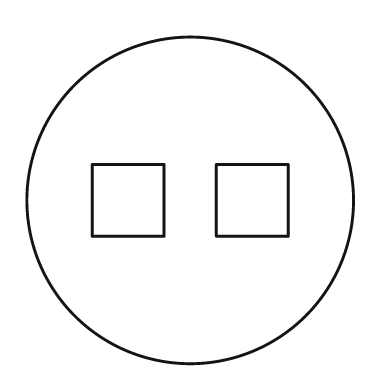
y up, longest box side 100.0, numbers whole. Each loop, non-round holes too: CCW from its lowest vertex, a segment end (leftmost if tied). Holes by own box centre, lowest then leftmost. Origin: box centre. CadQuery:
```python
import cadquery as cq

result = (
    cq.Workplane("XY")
    .moveTo(0.0, 0.0)
    .circle(50.0)
    .moveTo(-30.0, -11.0)
    .lineTo(-8.0, -11.0)
    .lineTo(-8.0, 11.0)
    .lineTo(-30.0, 11.0)
    .close()
    .moveTo(8.0, -11.0)
    .lineTo(30.0, -11.0)
    .lineTo(30.0, 11.0)
    .lineTo(8.0, 11.0)
    .close()
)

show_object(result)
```